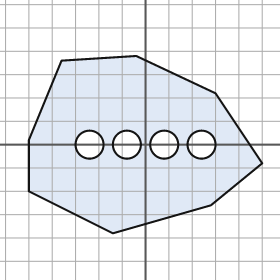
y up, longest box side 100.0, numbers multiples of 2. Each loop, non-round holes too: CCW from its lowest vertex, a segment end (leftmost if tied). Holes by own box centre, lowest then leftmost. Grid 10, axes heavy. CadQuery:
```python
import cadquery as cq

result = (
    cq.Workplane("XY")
    .moveTo(-14.0, -38.0)
    .lineTo(28.0, -26.0)
    .lineTo(50.0, -8.0)
    .lineTo(30.0, 22.0)
    .lineTo(-4.0, 38.0)
    .lineTo(-36.0, 36.0)
    .lineTo(-50.0, 2.0)
    .lineTo(-50.0, -20.0)
    .close()
    .moveTo(-24.0, 0.0)
    .circle(6.0)
    .moveTo(-8.0, 0.0)
    .circle(6.0)
    .moveTo(8.0, 0.0)
    .circle(6.0)
    .moveTo(24.0, 0.0)
    .circle(6.0)
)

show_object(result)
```